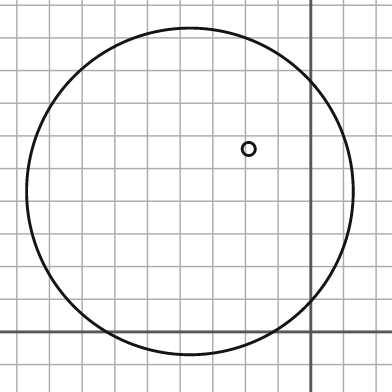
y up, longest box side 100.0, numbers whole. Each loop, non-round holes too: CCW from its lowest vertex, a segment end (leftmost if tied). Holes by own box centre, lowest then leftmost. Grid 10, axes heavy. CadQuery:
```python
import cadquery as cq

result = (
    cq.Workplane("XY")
    .moveTo(-37.0, 43.0)
    .circle(50.0)
    .moveTo(-19.0, 56.0)
    .circle(2.0)
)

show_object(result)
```